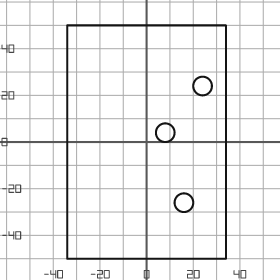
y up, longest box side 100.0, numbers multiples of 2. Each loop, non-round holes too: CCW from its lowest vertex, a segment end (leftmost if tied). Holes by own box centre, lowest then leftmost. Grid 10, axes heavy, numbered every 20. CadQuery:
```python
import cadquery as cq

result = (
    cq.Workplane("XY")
    .moveTo(-34.0, -50.0)
    .lineTo(34.0, -50.0)
    .lineTo(34.0, 50.0)
    .lineTo(-34.0, 50.0)
    .close()
    .moveTo(16.0, -26.0)
    .circle(4.0)
    .moveTo(8.0, 4.0)
    .circle(4.0)
    .moveTo(24.0, 24.0)
    .circle(4.0)
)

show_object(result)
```